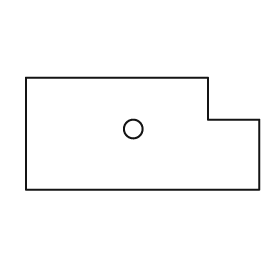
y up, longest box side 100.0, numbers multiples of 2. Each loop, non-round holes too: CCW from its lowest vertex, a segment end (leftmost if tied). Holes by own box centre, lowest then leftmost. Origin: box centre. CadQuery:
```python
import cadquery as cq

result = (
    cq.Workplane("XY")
    .moveTo(-50.0, -24.0)
    .lineTo(50.0, -24.0)
    .lineTo(50.0, 6.0)
    .lineTo(28.0, 6.0)
    .lineTo(28.0, 24.0)
    .lineTo(-50.0, 24.0)
    .close()
    .moveTo(-4.0, 2.0)
    .circle(4.0)
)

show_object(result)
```